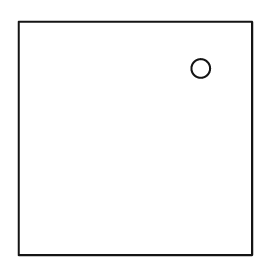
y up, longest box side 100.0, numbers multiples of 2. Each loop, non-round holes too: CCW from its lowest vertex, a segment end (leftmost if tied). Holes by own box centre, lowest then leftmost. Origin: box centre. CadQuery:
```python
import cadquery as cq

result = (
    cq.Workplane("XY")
    .moveTo(-50.0, -50.0)
    .lineTo(50.0, -50.0)
    .lineTo(50.0, 50.0)
    .lineTo(-50.0, 50.0)
    .close()
    .moveTo(28.0, 30.0)
    .circle(4.0)
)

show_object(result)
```